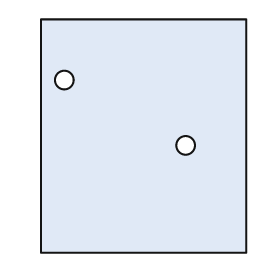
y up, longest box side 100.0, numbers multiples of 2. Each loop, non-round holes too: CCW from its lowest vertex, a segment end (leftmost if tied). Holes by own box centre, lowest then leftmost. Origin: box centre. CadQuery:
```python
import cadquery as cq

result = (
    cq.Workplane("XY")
    .moveTo(-44.0, -50.0)
    .lineTo(44.0, -50.0)
    .lineTo(44.0, 50.0)
    .lineTo(-44.0, 50.0)
    .close()
    .moveTo(18.0, -4.0)
    .circle(4.0)
    .moveTo(-34.0, 24.0)
    .circle(4.0)
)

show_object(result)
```